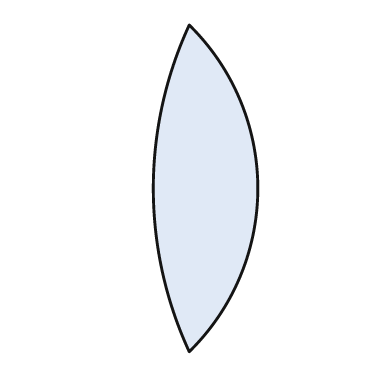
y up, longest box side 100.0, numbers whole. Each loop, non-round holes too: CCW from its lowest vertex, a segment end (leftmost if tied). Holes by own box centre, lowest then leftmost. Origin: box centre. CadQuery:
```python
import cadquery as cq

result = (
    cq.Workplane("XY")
    .moveTo(-5.0, -50.0)
    .threePointArc((16.0, 0.0), (-5.0, 50.0))
    .threePointArc((-16.0, 0.0), (-5.0, -50.0))
    .close()
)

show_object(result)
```